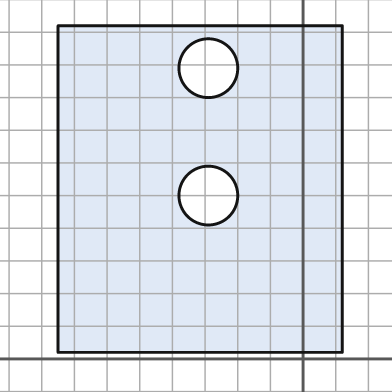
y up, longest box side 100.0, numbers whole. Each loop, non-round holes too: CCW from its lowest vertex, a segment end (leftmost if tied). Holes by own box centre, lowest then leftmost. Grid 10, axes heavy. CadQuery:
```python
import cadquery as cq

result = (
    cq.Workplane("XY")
    .moveTo(-75.0, 2.0)
    .lineTo(12.0, 2.0)
    .lineTo(12.0, 102.0)
    .lineTo(-75.0, 102.0)
    .close()
    .moveTo(-29.0, 50.0)
    .circle(9.0)
    .moveTo(-29.0, 89.0)
    .circle(9.0)
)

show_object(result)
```